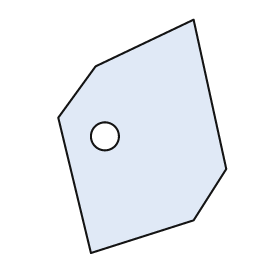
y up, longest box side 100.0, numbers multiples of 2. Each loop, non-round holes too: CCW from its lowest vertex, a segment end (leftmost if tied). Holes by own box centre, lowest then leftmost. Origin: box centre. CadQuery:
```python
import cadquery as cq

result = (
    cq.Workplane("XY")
    .moveTo(-22.0, -50.0)
    .lineTo(22.0, -36.0)
    .lineTo(36.0, -14.0)
    .lineTo(22.0, 50.0)
    .lineTo(-20.0, 30.0)
    .lineTo(-36.0, 8.0)
    .close()
    .moveTo(-16.0, 0.0)
    .circle(6.0)
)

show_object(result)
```